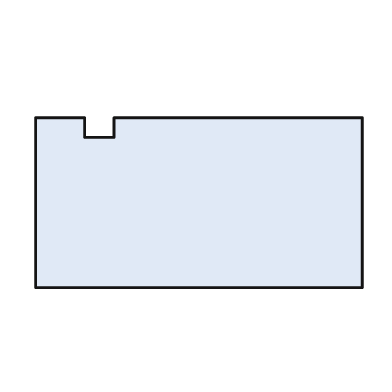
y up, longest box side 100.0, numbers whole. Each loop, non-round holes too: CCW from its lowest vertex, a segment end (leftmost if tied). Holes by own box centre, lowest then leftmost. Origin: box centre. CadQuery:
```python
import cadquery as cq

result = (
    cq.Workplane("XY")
    .moveTo(-50.0, -26.0)
    .lineTo(50.0, -26.0)
    .lineTo(50.0, 26.0)
    .lineTo(-26.0, 26.0)
    .lineTo(-26.0, 20.0)
    .lineTo(-35.0, 20.0)
    .lineTo(-35.0, 26.0)
    .lineTo(-50.0, 26.0)
    .close()
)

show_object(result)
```